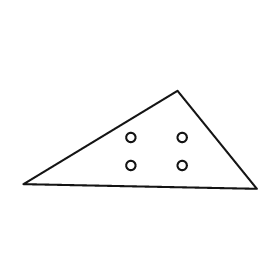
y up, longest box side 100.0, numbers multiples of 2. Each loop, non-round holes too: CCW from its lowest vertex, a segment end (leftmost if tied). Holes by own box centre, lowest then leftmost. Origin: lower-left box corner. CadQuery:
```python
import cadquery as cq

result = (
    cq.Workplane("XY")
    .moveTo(100.0, 0.0)
    .lineTo(66.0, 42.0)
    .lineTo(0.0, 2.0)
    .close()
    .moveTo(46.0, 10.0)
    .circle(2.0)
    .moveTo(68.0, 10.0)
    .circle(2.0)
    .moveTo(46.0, 22.0)
    .circle(2.0)
    .moveTo(68.0, 22.0)
    .circle(2.0)
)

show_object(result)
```